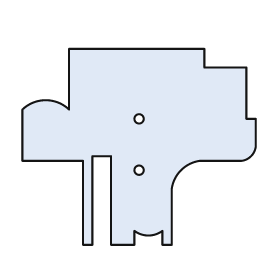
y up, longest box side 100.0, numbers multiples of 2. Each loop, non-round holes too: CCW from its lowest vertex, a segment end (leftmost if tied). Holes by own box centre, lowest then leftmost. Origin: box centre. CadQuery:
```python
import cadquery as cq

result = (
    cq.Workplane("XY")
    .moveTo(-24.0, -42.0)
    .lineTo(-20.0, -42.0)
    .lineTo(-20.0, -4.0)
    .lineTo(-12.0, -4.0)
    .lineTo(-12.0, -42.0)
    .lineTo(-2.0, -42.0)
    .lineTo(-2.0, -36.0)
    .threePointArc((4.0, -38.0), (10.0, -36.0))
    .lineTo(10.0, -42.0)
    .lineTo(14.0, -42.0)
    .lineTo(14.0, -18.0)
    .threePointArc((18.0, -10.0), (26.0, -6.0))
    .lineTo(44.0, -6.0)
    .threePointArc((48.0, -4.0), (50.0, 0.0))
    .lineTo(50.0, 12.0)
    .lineTo(46.0, 12.0)
    .lineTo(46.0, 34.0)
    .lineTo(28.0, 34.0)
    .lineTo(28.0, 42.0)
    .lineTo(-30.0, 42.0)
    .lineTo(-30.0, 16.0)
    .threePointArc((-40.0, 20.0), (-50.0, 16.0))
    .lineTo(-50.0, -6.0)
    .lineTo(-24.0, -6.0)
    .close()
    .moveTo(0.0, -10.0)
    .circle(2.0)
    .moveTo(0.0, 12.0)
    .circle(2.0)
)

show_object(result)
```